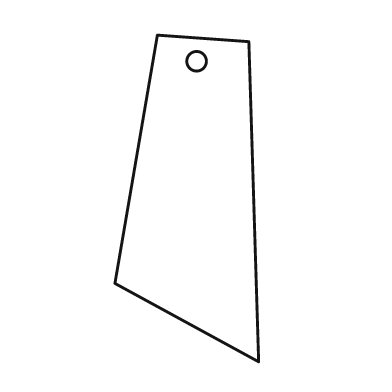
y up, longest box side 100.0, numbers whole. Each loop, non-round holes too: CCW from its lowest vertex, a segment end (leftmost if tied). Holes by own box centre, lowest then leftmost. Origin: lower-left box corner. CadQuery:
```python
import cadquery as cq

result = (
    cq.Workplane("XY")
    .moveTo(44.0, 0.0)
    .lineTo(41.0, 98.0)
    .lineTo(13.0, 100.0)
    .lineTo(0.0, 24.0)
    .close()
    .moveTo(25.0, 92.0)
    .circle(3.0)
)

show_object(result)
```